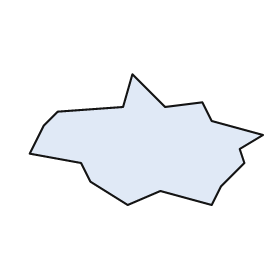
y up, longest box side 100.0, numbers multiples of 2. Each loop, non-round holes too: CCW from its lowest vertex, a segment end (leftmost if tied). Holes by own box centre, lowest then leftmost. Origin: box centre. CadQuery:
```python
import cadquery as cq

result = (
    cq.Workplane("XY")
    .moveTo(-8.0, -28.0)
    .lineTo(6.0, -22.0)
    .lineTo(28.0, -28.0)
    .lineTo(32.0, -20.0)
    .lineTo(42.0, -10.0)
    .lineTo(40.0, -4.0)
    .lineTo(50.0, 2.0)
    .lineTo(28.0, 8.0)
    .lineTo(24.0, 16.0)
    .lineTo(8.0, 14.0)
    .lineTo(-6.0, 28.0)
    .lineTo(-10.0, 14.0)
    .lineTo(-38.0, 12.0)
    .lineTo(-44.0, 6.0)
    .lineTo(-50.0, -6.0)
    .lineTo(-28.0, -10.0)
    .lineTo(-24.0, -18.0)
    .close()
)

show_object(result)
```